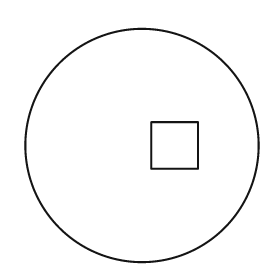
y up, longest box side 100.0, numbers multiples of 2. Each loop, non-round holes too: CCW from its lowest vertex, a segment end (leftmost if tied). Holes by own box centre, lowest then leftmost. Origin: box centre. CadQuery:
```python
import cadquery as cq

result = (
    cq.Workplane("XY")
    .moveTo(0.0, 0.0)
    .circle(50.0)
    .moveTo(4.0, -10.0)
    .lineTo(24.0, -10.0)
    .lineTo(24.0, 10.0)
    .lineTo(4.0, 10.0)
    .close()
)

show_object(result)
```